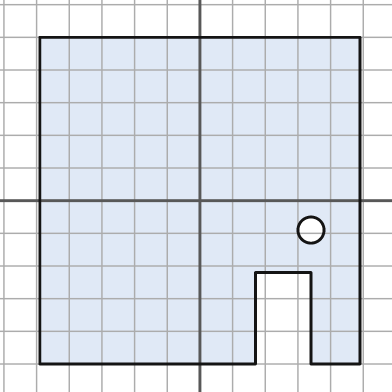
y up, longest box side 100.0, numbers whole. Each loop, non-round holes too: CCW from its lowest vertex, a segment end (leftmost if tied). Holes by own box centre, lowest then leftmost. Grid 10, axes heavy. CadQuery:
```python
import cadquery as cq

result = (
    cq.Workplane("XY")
    .moveTo(-49.0, -50.0)
    .lineTo(17.0, -50.0)
    .lineTo(17.0, -22.0)
    .lineTo(34.0, -22.0)
    .lineTo(34.0, -50.0)
    .lineTo(49.0, -50.0)
    .lineTo(49.0, 50.0)
    .lineTo(-49.0, 50.0)
    .close()
    .moveTo(34.0, -9.0)
    .circle(4.0)
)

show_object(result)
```